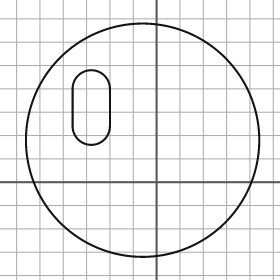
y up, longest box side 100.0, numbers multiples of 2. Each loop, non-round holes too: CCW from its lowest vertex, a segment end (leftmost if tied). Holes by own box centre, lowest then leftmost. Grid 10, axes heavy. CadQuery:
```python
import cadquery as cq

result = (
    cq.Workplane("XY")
    .moveTo(-6.0, 18.0)
    .circle(50.0)
    .moveTo(-36.0, 24.0)
    .threePointArc((-28.0, 16.0), (-20.0, 24.0))
    .lineTo(-20.0, 40.0)
    .threePointArc((-28.0, 48.0), (-36.0, 40.0))
    .close()
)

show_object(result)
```